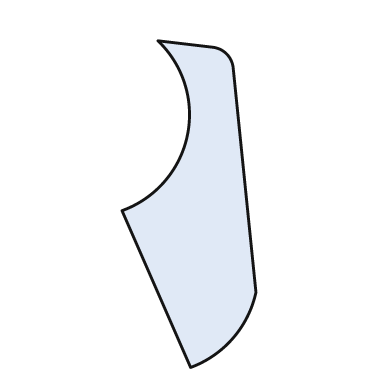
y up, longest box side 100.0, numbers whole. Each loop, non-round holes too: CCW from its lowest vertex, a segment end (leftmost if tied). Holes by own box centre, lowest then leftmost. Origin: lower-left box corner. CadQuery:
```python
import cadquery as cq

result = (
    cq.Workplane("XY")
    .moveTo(21.0, 0.0)
    .threePointArc((34.0, 9.0), (41.0, 23.0))
    .lineTo(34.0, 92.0)
    .threePointArc((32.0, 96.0), (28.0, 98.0))
    .lineTo(11.0, 100.0)
    .threePointArc((20.0, 71.0), (0.0, 48.0))
    .close()
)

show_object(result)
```